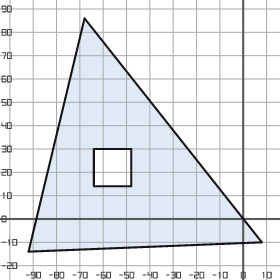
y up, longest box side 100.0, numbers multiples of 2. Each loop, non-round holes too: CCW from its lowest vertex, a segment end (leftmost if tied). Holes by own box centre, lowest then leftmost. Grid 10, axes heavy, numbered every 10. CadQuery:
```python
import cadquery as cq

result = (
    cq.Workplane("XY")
    .moveTo(-92.0, -14.0)
    .lineTo(8.0, -10.0)
    .lineTo(-68.0, 86.0)
    .close()
    .moveTo(-64.0, 14.0)
    .lineTo(-48.0, 14.0)
    .lineTo(-48.0, 30.0)
    .lineTo(-64.0, 30.0)
    .close()
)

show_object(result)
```